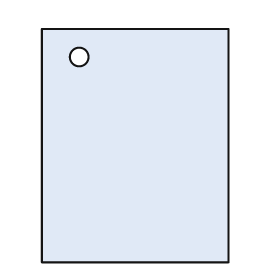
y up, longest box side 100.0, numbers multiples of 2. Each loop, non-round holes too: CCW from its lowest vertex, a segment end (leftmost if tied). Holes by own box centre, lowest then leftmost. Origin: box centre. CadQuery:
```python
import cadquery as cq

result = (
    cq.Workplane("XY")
    .moveTo(-40.0, -50.0)
    .lineTo(40.0, -50.0)
    .lineTo(40.0, 50.0)
    .lineTo(-40.0, 50.0)
    .close()
    .moveTo(-24.0, 38.0)
    .circle(4.0)
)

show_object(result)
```